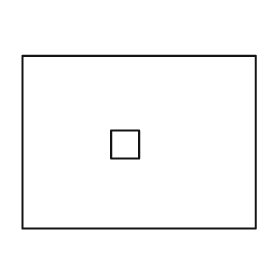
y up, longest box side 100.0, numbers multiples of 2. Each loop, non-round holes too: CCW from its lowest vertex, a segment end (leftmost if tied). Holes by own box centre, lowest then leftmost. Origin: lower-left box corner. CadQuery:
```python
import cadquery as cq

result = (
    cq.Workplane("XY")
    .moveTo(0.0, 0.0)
    .lineTo(100.0, 0.0)
    .lineTo(100.0, 74.0)
    .lineTo(0.0, 74.0)
    .close()
    .moveTo(38.0, 30.0)
    .lineTo(50.0, 30.0)
    .lineTo(50.0, 42.0)
    .lineTo(38.0, 42.0)
    .close()
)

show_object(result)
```